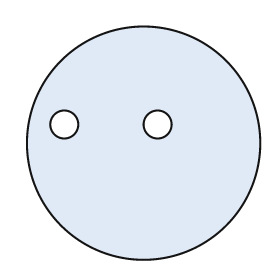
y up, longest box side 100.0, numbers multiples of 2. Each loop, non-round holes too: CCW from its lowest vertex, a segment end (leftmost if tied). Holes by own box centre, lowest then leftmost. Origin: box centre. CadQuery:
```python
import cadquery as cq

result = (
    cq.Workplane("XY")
    .moveTo(0.0, 0.0)
    .circle(50.0)
    .moveTo(-34.0, 8.0)
    .circle(6.0)
    .moveTo(6.0, 8.0)
    .circle(6.0)
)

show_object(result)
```